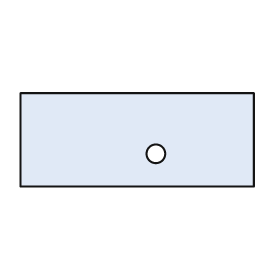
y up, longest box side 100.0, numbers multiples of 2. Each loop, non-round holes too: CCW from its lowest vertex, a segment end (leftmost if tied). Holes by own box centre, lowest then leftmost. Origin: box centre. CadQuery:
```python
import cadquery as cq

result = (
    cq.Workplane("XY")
    .moveTo(-50.0, -20.0)
    .lineTo(50.0, -20.0)
    .lineTo(50.0, 20.0)
    .lineTo(-50.0, 20.0)
    .close()
    .moveTo(8.0, -6.0)
    .circle(4.0)
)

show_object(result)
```